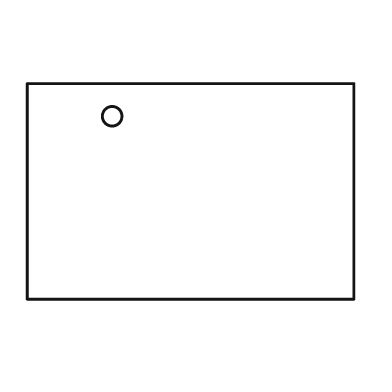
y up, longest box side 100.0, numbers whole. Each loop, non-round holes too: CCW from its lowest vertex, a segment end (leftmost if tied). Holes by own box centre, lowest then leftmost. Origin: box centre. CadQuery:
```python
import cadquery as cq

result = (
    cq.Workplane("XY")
    .moveTo(-50.0, -33.0)
    .lineTo(50.0, -33.0)
    .lineTo(50.0, 33.0)
    .lineTo(-50.0, 33.0)
    .close()
    .moveTo(-24.0, 23.0)
    .circle(3.0)
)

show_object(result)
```